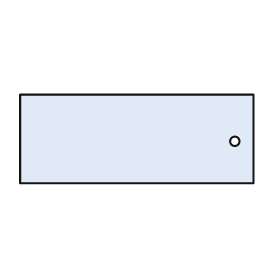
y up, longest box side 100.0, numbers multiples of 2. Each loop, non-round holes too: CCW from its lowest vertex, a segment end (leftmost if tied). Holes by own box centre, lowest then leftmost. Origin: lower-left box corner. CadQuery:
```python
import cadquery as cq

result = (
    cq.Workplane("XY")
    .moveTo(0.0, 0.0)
    .lineTo(100.0, 0.0)
    .lineTo(100.0, 38.0)
    .lineTo(0.0, 38.0)
    .close()
    .moveTo(92.0, 18.0)
    .circle(2.0)
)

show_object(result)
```